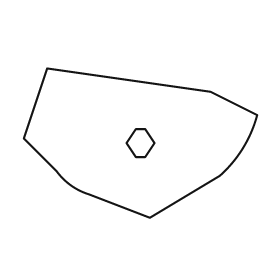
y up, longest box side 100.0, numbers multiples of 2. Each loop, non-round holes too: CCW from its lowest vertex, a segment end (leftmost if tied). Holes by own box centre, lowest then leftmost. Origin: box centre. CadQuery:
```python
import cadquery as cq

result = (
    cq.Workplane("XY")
    .moveTo(4.0, -32.0)
    .lineTo(34.0, -14.0)
    .threePointArc((44.0, -2.0), (50.0, 12.0))
    .lineTo(30.0, 22.0)
    .lineTo(-40.0, 32.0)
    .lineTo(-50.0, 2.0)
    .lineTo(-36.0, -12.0)
    .threePointArc((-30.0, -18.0), (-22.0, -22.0))
    .close()
    .moveTo(-2.0, -6.0)
    .lineTo(2.0, -6.0)
    .lineTo(6.0, 0.0)
    .lineTo(2.0, 6.0)
    .lineTo(-2.0, 6.0)
    .lineTo(-6.0, 0.0)
    .close()
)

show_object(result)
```